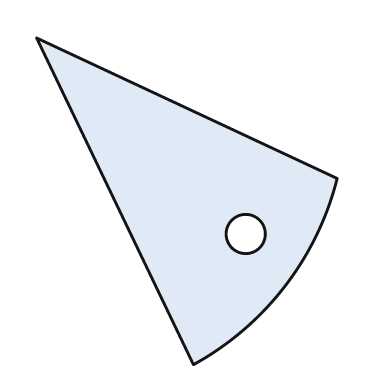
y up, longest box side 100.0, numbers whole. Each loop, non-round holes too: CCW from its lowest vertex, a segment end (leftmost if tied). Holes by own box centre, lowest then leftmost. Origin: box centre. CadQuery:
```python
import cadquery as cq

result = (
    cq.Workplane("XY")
    .moveTo(2.0, -50.0)
    .threePointArc((30.0, -26.0), (46.0, 7.0))
    .lineTo(-46.0, 50.0)
    .close()
    .moveTo(18.0, -10.0)
    .circle(6.0)
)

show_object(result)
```